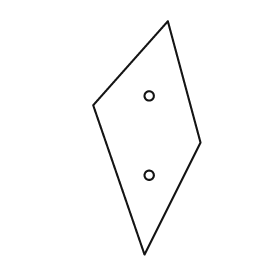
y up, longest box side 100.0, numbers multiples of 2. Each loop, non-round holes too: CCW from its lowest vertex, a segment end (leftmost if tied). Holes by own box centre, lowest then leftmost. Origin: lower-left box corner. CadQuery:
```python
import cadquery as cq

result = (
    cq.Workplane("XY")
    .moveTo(22.0, 0.0)
    .lineTo(46.0, 48.0)
    .lineTo(32.0, 100.0)
    .lineTo(0.0, 64.0)
    .close()
    .moveTo(24.0, 34.0)
    .circle(2.0)
    .moveTo(24.0, 68.0)
    .circle(2.0)
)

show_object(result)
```